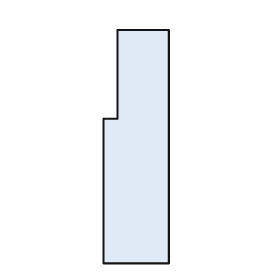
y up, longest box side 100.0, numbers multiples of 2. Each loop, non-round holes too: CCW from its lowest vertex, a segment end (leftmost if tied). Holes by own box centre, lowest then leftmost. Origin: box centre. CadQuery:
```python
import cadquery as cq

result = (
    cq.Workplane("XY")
    .moveTo(-14.0, -50.0)
    .lineTo(14.0, -50.0)
    .lineTo(14.0, 50.0)
    .lineTo(-8.0, 50.0)
    .lineTo(-8.0, 12.0)
    .lineTo(-14.0, 12.0)
    .close()
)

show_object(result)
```